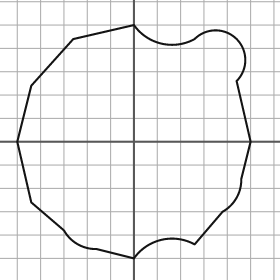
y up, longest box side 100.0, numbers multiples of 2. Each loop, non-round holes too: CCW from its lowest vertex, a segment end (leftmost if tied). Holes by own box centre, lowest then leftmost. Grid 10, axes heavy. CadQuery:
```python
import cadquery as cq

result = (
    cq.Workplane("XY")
    .moveTo(0.0, -50.0)
    .threePointArc((12.0, -42.0), (26.0, -44.0))
    .lineTo(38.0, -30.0)
    .threePointArc((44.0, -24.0), (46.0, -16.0))
    .lineTo(50.0, 0.0)
    .lineTo(44.0, 26.0)
    .threePointArc((44.0, 44.0), (26.0, 44.0))
    .threePointArc((12.0, 42.0), (0.0, 50.0))
    .lineTo(-26.0, 44.0)
    .lineTo(-44.0, 24.0)
    .lineTo(-50.0, 0.0)
    .lineTo(-44.0, -26.0)
    .lineTo(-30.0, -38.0)
    .threePointArc((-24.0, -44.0), (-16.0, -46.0))
    .close()
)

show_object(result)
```